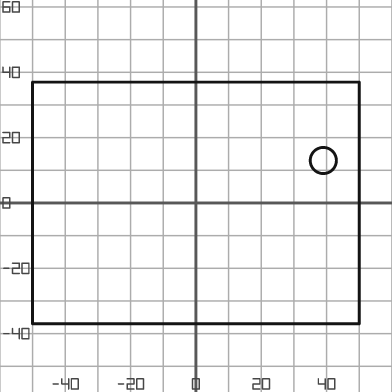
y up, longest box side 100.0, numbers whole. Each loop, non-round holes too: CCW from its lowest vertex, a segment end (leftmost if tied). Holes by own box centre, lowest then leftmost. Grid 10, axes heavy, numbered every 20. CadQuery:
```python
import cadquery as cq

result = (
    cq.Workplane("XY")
    .moveTo(-50.0, -37.0)
    .lineTo(50.0, -37.0)
    .lineTo(50.0, 37.0)
    .lineTo(-50.0, 37.0)
    .close()
    .moveTo(39.0, 13.0)
    .circle(4.0)
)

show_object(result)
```